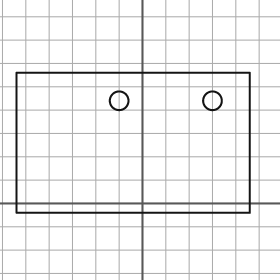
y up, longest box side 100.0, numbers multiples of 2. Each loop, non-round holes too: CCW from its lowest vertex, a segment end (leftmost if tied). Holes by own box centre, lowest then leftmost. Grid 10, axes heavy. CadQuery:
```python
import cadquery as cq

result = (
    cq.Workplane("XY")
    .moveTo(-54.0, -4.0)
    .lineTo(46.0, -4.0)
    .lineTo(46.0, 56.0)
    .lineTo(-54.0, 56.0)
    .close()
    .moveTo(-10.0, 44.0)
    .circle(4.0)
    .moveTo(30.0, 44.0)
    .circle(4.0)
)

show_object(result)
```